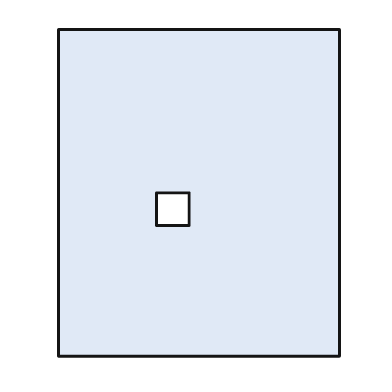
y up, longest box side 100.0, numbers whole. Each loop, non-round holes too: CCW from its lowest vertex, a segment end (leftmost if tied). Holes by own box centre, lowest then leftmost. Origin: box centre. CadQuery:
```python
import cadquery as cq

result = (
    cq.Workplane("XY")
    .moveTo(-43.0, -50.0)
    .lineTo(43.0, -50.0)
    .lineTo(43.0, 50.0)
    .lineTo(-43.0, 50.0)
    .close()
    .moveTo(-13.0, -10.0)
    .lineTo(-3.0, -10.0)
    .lineTo(-3.0, 0.0)
    .lineTo(-13.0, 0.0)
    .close()
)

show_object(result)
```